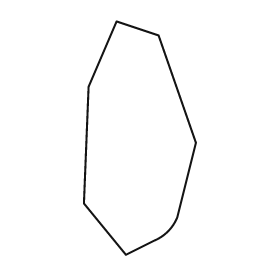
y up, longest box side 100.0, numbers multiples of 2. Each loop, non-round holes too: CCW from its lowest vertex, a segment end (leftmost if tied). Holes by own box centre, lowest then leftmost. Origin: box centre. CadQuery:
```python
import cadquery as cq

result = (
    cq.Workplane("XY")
    .moveTo(-6.0, -50.0)
    .lineTo(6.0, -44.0)
    .threePointArc((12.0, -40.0), (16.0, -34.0))
    .lineTo(24.0, -2.0)
    .lineTo(8.0, 44.0)
    .lineTo(-10.0, 50.0)
    .lineTo(-22.0, 22.0)
    .lineTo(-24.0, -28.0)
    .close()
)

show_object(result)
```